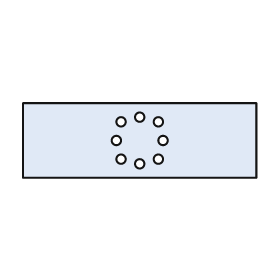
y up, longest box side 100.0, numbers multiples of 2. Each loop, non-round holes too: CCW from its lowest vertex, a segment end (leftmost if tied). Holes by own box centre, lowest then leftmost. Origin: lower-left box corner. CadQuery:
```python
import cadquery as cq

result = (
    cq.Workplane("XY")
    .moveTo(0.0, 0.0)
    .lineTo(100.0, 0.0)
    .lineTo(100.0, 32.0)
    .lineTo(0.0, 32.0)
    .close()
    .moveTo(50.0, 6.0)
    .circle(2.0)
    .moveTo(42.0, 8.0)
    .circle(2.0)
    .moveTo(58.0, 8.0)
    .circle(2.0)
    .moveTo(40.0, 16.0)
    .circle(2.0)
    .moveTo(60.0, 16.0)
    .circle(2.0)
    .moveTo(42.0, 24.0)
    .circle(2.0)
    .moveTo(58.0, 24.0)
    .circle(2.0)
    .moveTo(50.0, 26.0)
    .circle(2.0)
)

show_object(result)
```